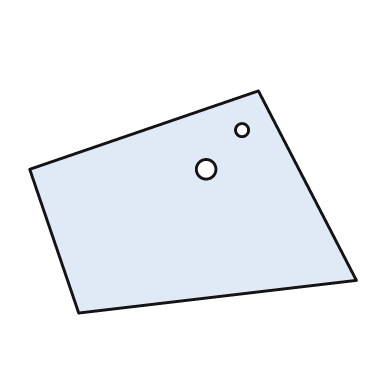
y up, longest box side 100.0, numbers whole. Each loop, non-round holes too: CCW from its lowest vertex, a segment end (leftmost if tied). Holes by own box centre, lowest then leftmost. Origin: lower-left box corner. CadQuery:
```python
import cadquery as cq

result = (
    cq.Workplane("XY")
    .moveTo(15.0, 0.0)
    .lineTo(100.0, 10.0)
    .lineTo(70.0, 68.0)
    .lineTo(0.0, 44.0)
    .close()
    .moveTo(54.0, 44.0)
    .circle(3.0)
    .moveTo(65.0, 56.0)
    .circle(2.0)
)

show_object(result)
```